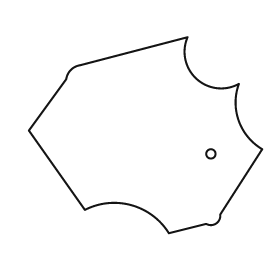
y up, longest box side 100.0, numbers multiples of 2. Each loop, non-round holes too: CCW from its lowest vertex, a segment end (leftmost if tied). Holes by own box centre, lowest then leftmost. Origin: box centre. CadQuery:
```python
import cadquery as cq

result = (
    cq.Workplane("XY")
    .moveTo(10.0, -42.0)
    .lineTo(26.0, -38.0)
    .threePointArc((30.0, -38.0), (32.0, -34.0))
    .lineTo(50.0, -6.0)
    .threePointArc((40.0, 6.0), (40.0, 22.0))
    .threePointArc((22.0, 24.0), (18.0, 42.0))
    .lineTo(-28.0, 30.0)
    .threePointArc((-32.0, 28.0), (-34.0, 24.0))
    .lineTo(-50.0, 2.0)
    .lineTo(-26.0, -32.0)
    .threePointArc((-6.0, -30.0), (10.0, -42.0))
    .close()
    .moveTo(28.0, -8.0)
    .circle(2.0)
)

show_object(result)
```